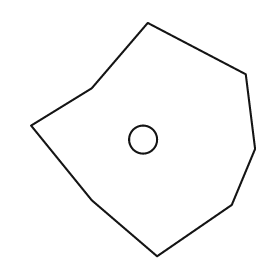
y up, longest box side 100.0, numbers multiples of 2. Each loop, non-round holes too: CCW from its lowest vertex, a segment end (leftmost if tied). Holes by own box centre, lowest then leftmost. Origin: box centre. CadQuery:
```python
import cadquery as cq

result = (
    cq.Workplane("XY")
    .moveTo(6.0, -50.0)
    .lineTo(38.0, -28.0)
    .lineTo(48.0, -4.0)
    .lineTo(44.0, 28.0)
    .lineTo(2.0, 50.0)
    .lineTo(-22.0, 22.0)
    .lineTo(-48.0, 6.0)
    .lineTo(-22.0, -26.0)
    .close()
    .moveTo(0.0, 0.0)
    .circle(6.0)
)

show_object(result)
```